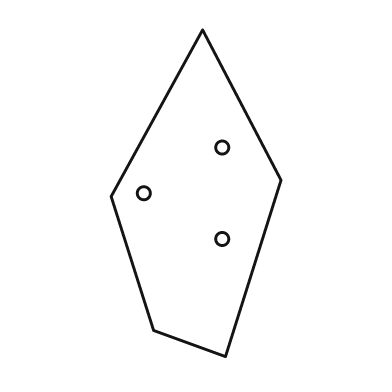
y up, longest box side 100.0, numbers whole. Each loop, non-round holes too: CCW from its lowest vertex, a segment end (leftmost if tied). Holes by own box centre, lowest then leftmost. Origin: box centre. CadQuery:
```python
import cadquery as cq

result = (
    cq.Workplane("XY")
    .moveTo(9.0, -50.0)
    .lineTo(26.0, 4.0)
    .lineTo(2.0, 50.0)
    .lineTo(-26.0, -1.0)
    .lineTo(-13.0, -42.0)
    .close()
    .moveTo(8.0, -14.0)
    .circle(2.0)
    .moveTo(-16.0, 0.0)
    .circle(2.0)
    .moveTo(8.0, 14.0)
    .circle(2.0)
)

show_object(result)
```